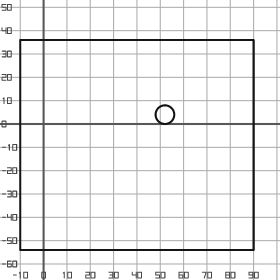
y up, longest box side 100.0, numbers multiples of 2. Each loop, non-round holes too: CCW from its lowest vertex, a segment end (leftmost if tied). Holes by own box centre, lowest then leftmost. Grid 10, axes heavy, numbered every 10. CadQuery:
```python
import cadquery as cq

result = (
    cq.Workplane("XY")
    .moveTo(-10.0, -54.0)
    .lineTo(90.0, -54.0)
    .lineTo(90.0, 36.0)
    .lineTo(-10.0, 36.0)
    .close()
    .moveTo(52.0, 4.0)
    .circle(4.0)
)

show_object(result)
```